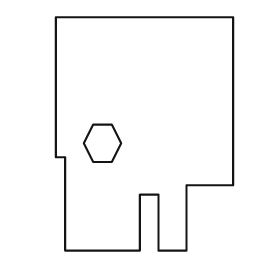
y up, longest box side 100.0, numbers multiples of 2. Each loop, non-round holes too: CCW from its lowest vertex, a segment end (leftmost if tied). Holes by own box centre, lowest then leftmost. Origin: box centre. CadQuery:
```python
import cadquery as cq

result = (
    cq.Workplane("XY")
    .moveTo(-34.0, -50.0)
    .lineTo(-2.0, -50.0)
    .lineTo(-2.0, -26.0)
    .lineTo(6.0, -26.0)
    .lineTo(6.0, -50.0)
    .lineTo(18.0, -50.0)
    .lineTo(18.0, -22.0)
    .lineTo(38.0, -22.0)
    .lineTo(38.0, 50.0)
    .lineTo(-38.0, 50.0)
    .lineTo(-38.0, -10.0)
    .lineTo(-34.0, -10.0)
    .close()
    .moveTo(-22.0, -12.0)
    .lineTo(-14.0, -12.0)
    .lineTo(-10.0, -4.0)
    .lineTo(-14.0, 4.0)
    .lineTo(-22.0, 4.0)
    .lineTo(-26.0, -4.0)
    .close()
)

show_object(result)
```